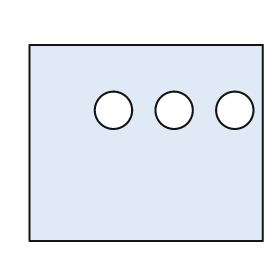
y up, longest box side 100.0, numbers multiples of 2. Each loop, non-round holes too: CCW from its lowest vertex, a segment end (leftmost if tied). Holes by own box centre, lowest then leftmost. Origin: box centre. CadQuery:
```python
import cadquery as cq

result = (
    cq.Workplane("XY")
    .moveTo(-50.0, -42.0)
    .lineTo(50.0, -42.0)
    .lineTo(50.0, 42.0)
    .lineTo(-50.0, 42.0)
    .close()
    .moveTo(-14.0, 14.0)
    .circle(8.0)
    .moveTo(12.0, 14.0)
    .circle(8.0)
    .moveTo(38.0, 14.0)
    .circle(8.0)
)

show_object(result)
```